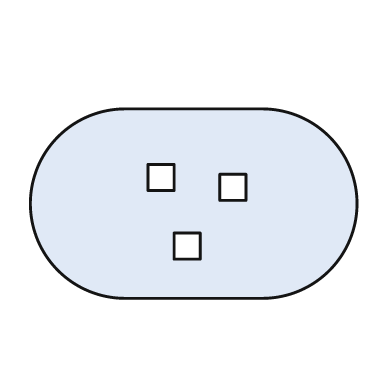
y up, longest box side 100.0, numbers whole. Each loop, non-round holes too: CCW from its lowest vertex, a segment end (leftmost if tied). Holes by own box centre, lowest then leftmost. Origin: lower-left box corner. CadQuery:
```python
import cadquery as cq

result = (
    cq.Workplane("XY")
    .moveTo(29.0, 0.0)
    .lineTo(71.0, 0.0)
    .threePointArc((100.0, 29.0), (71.0, 58.0))
    .lineTo(29.0, 58.0)
    .threePointArc((0.0, 29.0), (29.0, 0.0))
    .close()
    .moveTo(44.0, 12.0)
    .lineTo(52.0, 12.0)
    .lineTo(52.0, 20.0)
    .lineTo(44.0, 20.0)
    .close()
    .moveTo(58.0, 30.0)
    .lineTo(66.0, 30.0)
    .lineTo(66.0, 38.0)
    .lineTo(58.0, 38.0)
    .close()
    .moveTo(36.0, 33.0)
    .lineTo(44.0, 33.0)
    .lineTo(44.0, 41.0)
    .lineTo(36.0, 41.0)
    .close()
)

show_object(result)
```